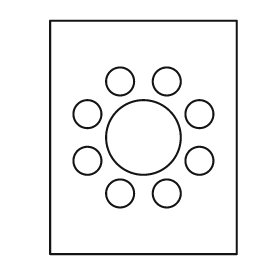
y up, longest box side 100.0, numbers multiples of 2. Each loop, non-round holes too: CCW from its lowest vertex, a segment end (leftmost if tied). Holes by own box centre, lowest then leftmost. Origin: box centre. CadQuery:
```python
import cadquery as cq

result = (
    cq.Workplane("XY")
    .moveTo(-40.0, -50.0)
    .lineTo(40.0, -50.0)
    .lineTo(40.0, 50.0)
    .lineTo(-40.0, 50.0)
    .close()
    .moveTo(-10.0, -24.0)
    .circle(6.0)
    .moveTo(10.0, -24.0)
    .circle(6.0)
    .moveTo(-24.0, -10.0)
    .circle(6.0)
    .moveTo(24.0, -10.0)
    .circle(6.0)
    .moveTo(0.0, 0.0)
    .circle(16.0)
    .moveTo(-24.0, 10.0)
    .circle(6.0)
    .moveTo(24.0, 10.0)
    .circle(6.0)
    .moveTo(-10.0, 24.0)
    .circle(6.0)
    .moveTo(10.0, 24.0)
    .circle(6.0)
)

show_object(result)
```